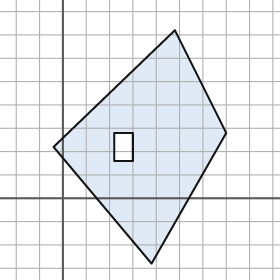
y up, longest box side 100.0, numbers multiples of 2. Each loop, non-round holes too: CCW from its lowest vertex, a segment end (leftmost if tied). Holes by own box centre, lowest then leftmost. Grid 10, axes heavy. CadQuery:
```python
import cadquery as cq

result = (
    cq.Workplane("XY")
    .moveTo(38.0, -28.0)
    .lineTo(70.0, 28.0)
    .lineTo(48.0, 72.0)
    .lineTo(-4.0, 22.0)
    .close()
    .moveTo(22.0, 16.0)
    .lineTo(30.0, 16.0)
    .lineTo(30.0, 28.0)
    .lineTo(22.0, 28.0)
    .close()
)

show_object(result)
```